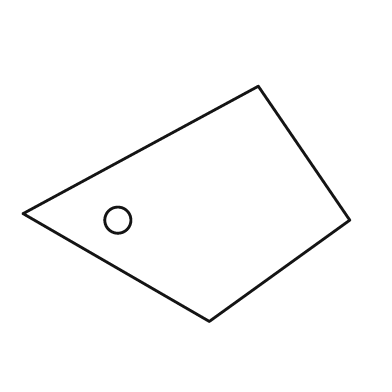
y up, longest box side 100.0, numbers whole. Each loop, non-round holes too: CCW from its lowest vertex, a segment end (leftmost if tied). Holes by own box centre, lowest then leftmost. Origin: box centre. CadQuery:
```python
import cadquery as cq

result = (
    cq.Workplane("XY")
    .moveTo(7.0, -36.0)
    .lineTo(50.0, -5.0)
    .lineTo(22.0, 36.0)
    .lineTo(-50.0, -3.0)
    .close()
    .moveTo(-21.0, -5.0)
    .circle(4.0)
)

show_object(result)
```